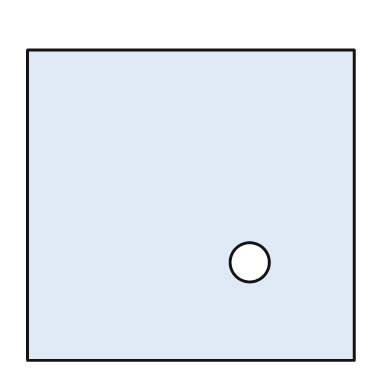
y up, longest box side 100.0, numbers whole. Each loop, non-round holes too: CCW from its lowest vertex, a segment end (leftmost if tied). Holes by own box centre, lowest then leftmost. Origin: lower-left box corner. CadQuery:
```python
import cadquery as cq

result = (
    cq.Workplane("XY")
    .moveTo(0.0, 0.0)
    .lineTo(100.0, 0.0)
    .lineTo(100.0, 95.0)
    .lineTo(0.0, 95.0)
    .close()
    .moveTo(68.0, 30.0)
    .circle(6.0)
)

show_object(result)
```